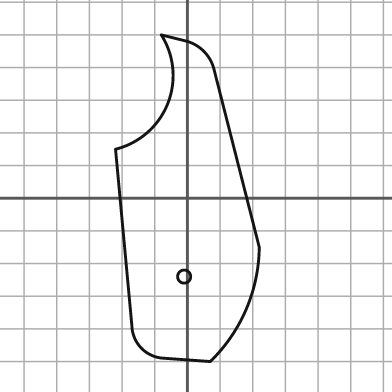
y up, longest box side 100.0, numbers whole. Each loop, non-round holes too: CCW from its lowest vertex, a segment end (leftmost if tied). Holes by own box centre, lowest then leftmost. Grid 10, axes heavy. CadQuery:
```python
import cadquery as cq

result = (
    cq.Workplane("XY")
    .moveTo(7.0, -50.0)
    .threePointArc((18.0, -34.0), (22.0, -15.0))
    .lineTo(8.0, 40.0)
    .threePointArc((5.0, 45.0), (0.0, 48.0))
    .lineTo(-8.0, 50.0)
    .threePointArc((-6.0, 29.0), (-22.0, 15.0))
    .lineTo(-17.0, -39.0)
    .threePointArc((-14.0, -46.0), (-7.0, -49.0))
    .close()
    .moveTo(-1.0, -24.0)
    .circle(2.0)
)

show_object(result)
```